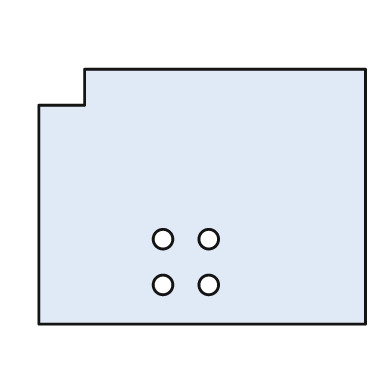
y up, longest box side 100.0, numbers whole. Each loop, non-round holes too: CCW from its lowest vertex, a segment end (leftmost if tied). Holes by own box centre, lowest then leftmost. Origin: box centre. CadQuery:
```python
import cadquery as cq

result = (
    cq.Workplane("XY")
    .moveTo(-50.0, -39.0)
    .lineTo(50.0, -39.0)
    .lineTo(50.0, 39.0)
    .lineTo(-36.0, 39.0)
    .lineTo(-36.0, 28.0)
    .lineTo(-50.0, 28.0)
    .close()
    .moveTo(-12.0, -27.0)
    .circle(3.0)
    .moveTo(2.0, -27.0)
    .circle(3.0)
    .moveTo(-12.0, -13.0)
    .circle(3.0)
    .moveTo(2.0, -13.0)
    .circle(3.0)
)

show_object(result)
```